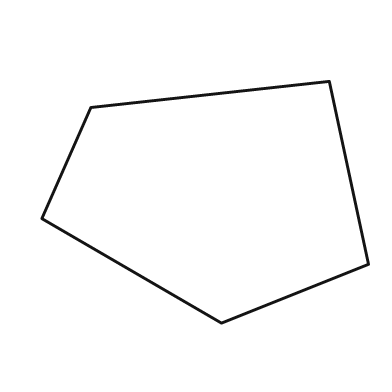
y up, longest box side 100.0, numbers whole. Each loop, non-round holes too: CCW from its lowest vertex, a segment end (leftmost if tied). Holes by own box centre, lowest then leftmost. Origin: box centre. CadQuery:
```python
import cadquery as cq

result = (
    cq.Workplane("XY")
    .moveTo(5.0, -37.0)
    .lineTo(50.0, -19.0)
    .lineTo(38.0, 37.0)
    .lineTo(-35.0, 29.0)
    .lineTo(-50.0, -5.0)
    .close()
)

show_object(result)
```